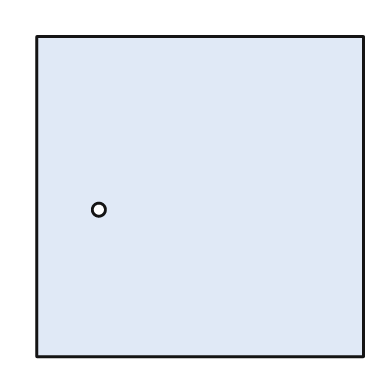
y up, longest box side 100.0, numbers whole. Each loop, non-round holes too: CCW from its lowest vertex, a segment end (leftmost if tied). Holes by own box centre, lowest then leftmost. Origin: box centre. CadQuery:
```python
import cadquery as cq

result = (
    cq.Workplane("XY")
    .moveTo(-50.0, -49.0)
    .lineTo(50.0, -49.0)
    .lineTo(50.0, 49.0)
    .lineTo(-50.0, 49.0)
    .close()
    .moveTo(-31.0, -4.0)
    .circle(2.0)
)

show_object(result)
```